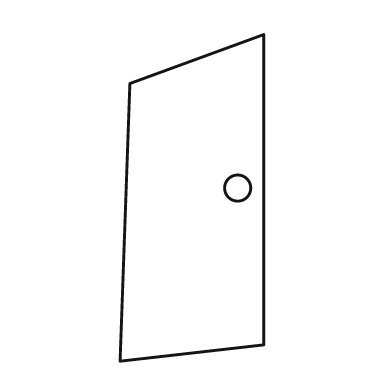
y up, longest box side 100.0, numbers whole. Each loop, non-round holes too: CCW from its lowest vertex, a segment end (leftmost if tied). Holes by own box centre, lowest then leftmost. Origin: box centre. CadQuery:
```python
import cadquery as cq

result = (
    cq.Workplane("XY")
    .moveTo(-22.0, -50.0)
    .lineTo(22.0, -45.0)
    .lineTo(22.0, 50.0)
    .lineTo(-19.0, 35.0)
    .close()
    .moveTo(14.0, 3.0)
    .circle(4.0)
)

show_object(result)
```